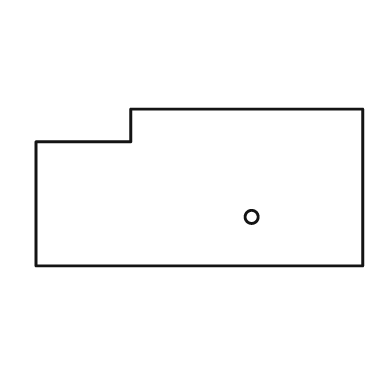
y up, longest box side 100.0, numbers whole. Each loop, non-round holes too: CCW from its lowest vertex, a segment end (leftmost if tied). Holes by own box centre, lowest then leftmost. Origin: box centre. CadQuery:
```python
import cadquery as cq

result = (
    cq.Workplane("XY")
    .moveTo(-50.0, -24.0)
    .lineTo(50.0, -24.0)
    .lineTo(50.0, 24.0)
    .lineTo(-21.0, 24.0)
    .lineTo(-21.0, 14.0)
    .lineTo(-50.0, 14.0)
    .close()
    .moveTo(16.0, -9.0)
    .circle(2.0)
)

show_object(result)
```